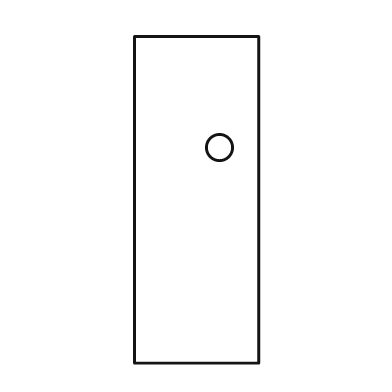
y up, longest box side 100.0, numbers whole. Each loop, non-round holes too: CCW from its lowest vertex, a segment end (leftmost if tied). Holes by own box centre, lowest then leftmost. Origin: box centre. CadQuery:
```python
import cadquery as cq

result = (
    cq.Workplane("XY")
    .moveTo(-19.0, -50.0)
    .lineTo(19.0, -50.0)
    .lineTo(19.0, 50.0)
    .lineTo(-19.0, 50.0)
    .close()
    .moveTo(7.0, 16.0)
    .circle(4.0)
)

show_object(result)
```